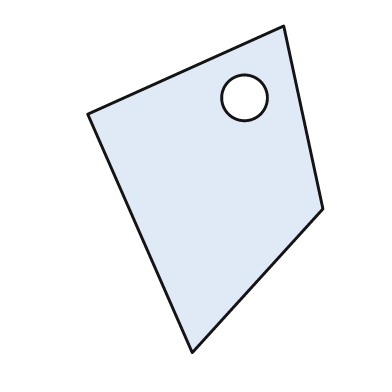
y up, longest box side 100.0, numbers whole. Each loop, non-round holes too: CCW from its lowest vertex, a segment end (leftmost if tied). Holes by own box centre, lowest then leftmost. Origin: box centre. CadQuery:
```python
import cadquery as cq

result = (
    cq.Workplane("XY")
    .moveTo(-4.0, -50.0)
    .lineTo(36.0, -6.0)
    .lineTo(24.0, 50.0)
    .lineTo(-36.0, 23.0)
    .close()
    .moveTo(12.0, 28.0)
    .circle(7.0)
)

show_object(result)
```